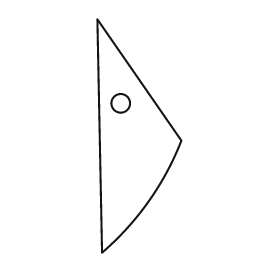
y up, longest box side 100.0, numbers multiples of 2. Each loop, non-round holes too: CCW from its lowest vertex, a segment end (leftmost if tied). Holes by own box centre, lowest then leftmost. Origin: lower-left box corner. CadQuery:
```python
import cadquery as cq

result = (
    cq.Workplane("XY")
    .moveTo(2.0, 0.0)
    .threePointArc((22.0, 22.0), (36.0, 48.0))
    .lineTo(0.0, 100.0)
    .close()
    .moveTo(10.0, 64.0)
    .circle(4.0)
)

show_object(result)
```